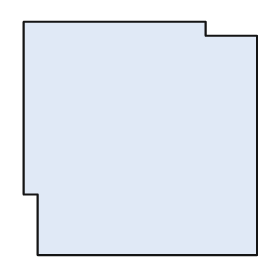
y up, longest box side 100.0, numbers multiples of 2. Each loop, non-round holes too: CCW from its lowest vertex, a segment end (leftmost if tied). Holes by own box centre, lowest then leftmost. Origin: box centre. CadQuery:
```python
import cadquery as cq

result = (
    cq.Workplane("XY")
    .moveTo(-44.0, -50.0)
    .lineTo(50.0, -50.0)
    .lineTo(50.0, 44.0)
    .lineTo(28.0, 44.0)
    .lineTo(28.0, 50.0)
    .lineTo(-50.0, 50.0)
    .lineTo(-50.0, -24.0)
    .lineTo(-44.0, -24.0)
    .close()
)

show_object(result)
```